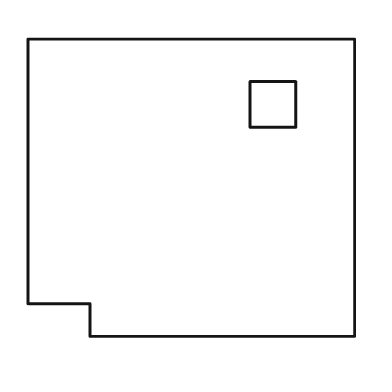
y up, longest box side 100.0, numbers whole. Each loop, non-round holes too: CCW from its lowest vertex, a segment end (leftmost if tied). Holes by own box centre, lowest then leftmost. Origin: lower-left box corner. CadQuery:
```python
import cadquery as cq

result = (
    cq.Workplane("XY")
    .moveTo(19.0, 0.0)
    .lineTo(100.0, 0.0)
    .lineTo(100.0, 91.0)
    .lineTo(0.0, 91.0)
    .lineTo(0.0, 10.0)
    .lineTo(19.0, 10.0)
    .close()
    .moveTo(68.0, 64.0)
    .lineTo(82.0, 64.0)
    .lineTo(82.0, 78.0)
    .lineTo(68.0, 78.0)
    .close()
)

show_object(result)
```